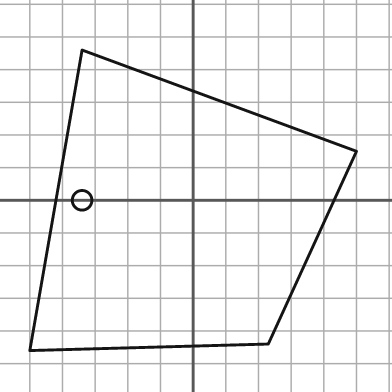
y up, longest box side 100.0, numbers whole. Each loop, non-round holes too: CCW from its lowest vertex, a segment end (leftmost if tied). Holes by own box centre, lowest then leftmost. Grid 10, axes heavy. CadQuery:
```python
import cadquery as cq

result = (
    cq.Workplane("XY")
    .moveTo(-50.0, -46.0)
    .lineTo(23.0, -44.0)
    .lineTo(50.0, 15.0)
    .lineTo(-34.0, 46.0)
    .close()
    .moveTo(-34.0, 0.0)
    .circle(3.0)
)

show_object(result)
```